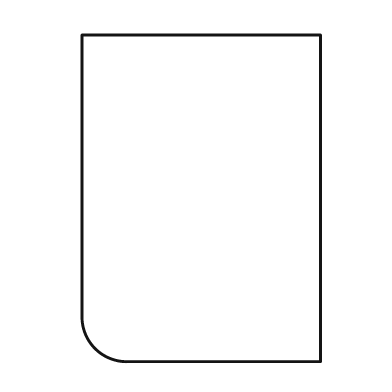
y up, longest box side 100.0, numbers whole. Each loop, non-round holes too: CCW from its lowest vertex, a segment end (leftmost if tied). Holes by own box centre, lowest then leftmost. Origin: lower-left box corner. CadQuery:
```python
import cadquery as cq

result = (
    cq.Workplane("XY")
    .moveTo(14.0, 0.0)
    .lineTo(73.0, 0.0)
    .lineTo(73.0, 100.0)
    .lineTo(0.0, 100.0)
    .lineTo(0.0, 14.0)
    .threePointArc((4.0, 4.0), (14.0, 0.0))
    .close()
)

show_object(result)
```